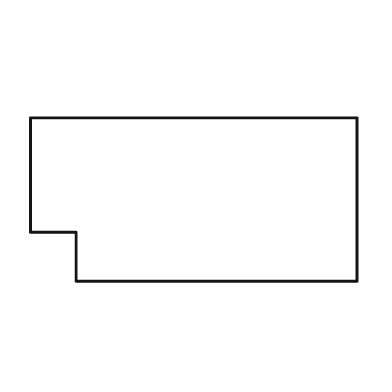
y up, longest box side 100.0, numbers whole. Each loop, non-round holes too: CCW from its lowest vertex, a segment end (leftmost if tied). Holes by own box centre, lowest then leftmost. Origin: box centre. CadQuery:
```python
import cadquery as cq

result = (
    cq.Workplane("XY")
    .moveTo(-36.0, -25.0)
    .lineTo(50.0, -25.0)
    .lineTo(50.0, 25.0)
    .lineTo(-50.0, 25.0)
    .lineTo(-50.0, -10.0)
    .lineTo(-36.0, -10.0)
    .close()
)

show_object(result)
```